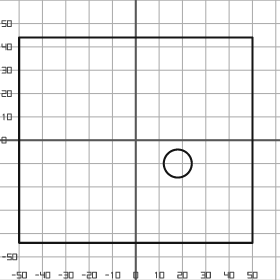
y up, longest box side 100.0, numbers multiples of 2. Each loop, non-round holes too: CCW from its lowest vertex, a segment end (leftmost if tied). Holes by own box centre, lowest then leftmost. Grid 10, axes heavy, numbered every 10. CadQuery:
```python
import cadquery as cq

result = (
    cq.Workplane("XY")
    .moveTo(-50.0, -44.0)
    .lineTo(50.0, -44.0)
    .lineTo(50.0, 44.0)
    .lineTo(-50.0, 44.0)
    .close()
    .moveTo(18.0, -10.0)
    .circle(6.0)
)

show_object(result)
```